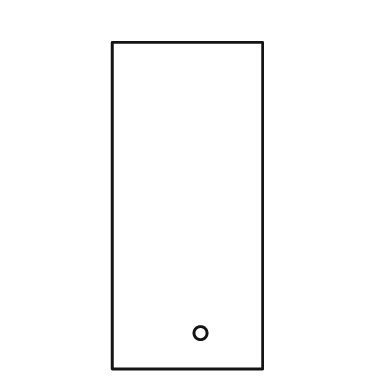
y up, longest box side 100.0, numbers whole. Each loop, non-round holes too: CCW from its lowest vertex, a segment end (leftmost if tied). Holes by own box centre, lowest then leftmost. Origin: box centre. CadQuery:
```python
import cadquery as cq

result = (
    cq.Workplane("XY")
    .moveTo(-23.0, -50.0)
    .lineTo(23.0, -50.0)
    .lineTo(23.0, 50.0)
    .lineTo(-23.0, 50.0)
    .close()
    .moveTo(4.0, -39.0)
    .circle(2.0)
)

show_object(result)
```